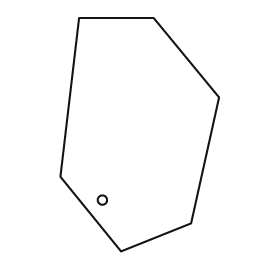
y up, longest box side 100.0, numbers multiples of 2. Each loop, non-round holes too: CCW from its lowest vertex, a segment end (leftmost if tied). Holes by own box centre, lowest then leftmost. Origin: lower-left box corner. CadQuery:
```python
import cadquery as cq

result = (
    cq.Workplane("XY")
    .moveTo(26.0, 0.0)
    .lineTo(56.0, 12.0)
    .lineTo(68.0, 66.0)
    .lineTo(40.0, 100.0)
    .lineTo(8.0, 100.0)
    .lineTo(0.0, 32.0)
    .close()
    .moveTo(18.0, 22.0)
    .circle(2.0)
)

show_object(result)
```